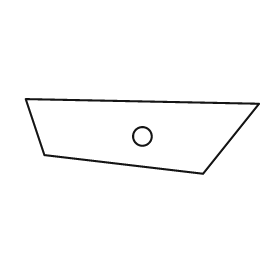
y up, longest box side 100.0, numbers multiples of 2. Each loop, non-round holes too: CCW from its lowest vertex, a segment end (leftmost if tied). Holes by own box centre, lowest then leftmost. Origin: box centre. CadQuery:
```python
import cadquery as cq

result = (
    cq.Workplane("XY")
    .moveTo(26.0, -16.0)
    .lineTo(50.0, 14.0)
    .lineTo(-50.0, 16.0)
    .lineTo(-42.0, -8.0)
    .close()
    .moveTo(0.0, 0.0)
    .circle(4.0)
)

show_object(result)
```